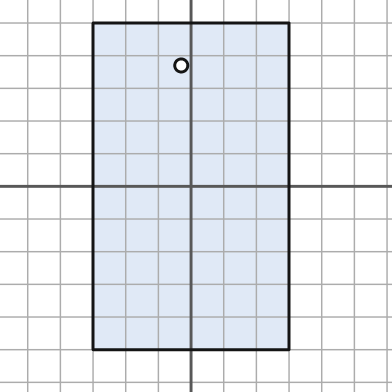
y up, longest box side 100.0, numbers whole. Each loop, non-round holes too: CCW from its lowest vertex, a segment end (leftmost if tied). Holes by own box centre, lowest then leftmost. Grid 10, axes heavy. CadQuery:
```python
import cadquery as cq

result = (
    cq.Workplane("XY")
    .moveTo(-30.0, -50.0)
    .lineTo(30.0, -50.0)
    .lineTo(30.0, 50.0)
    .lineTo(-30.0, 50.0)
    .close()
    .moveTo(-3.0, 37.0)
    .circle(2.0)
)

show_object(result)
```